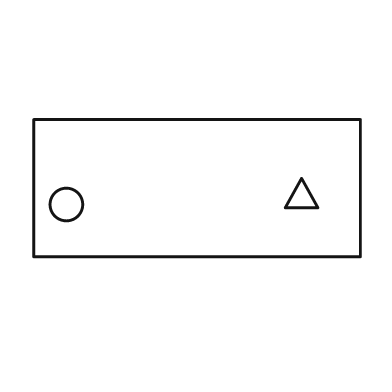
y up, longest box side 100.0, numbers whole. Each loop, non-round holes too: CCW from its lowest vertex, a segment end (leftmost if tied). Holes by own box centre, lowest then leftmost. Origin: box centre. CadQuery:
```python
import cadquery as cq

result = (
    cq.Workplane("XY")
    .moveTo(-50.0, -21.0)
    .lineTo(50.0, -21.0)
    .lineTo(50.0, 21.0)
    .lineTo(-50.0, 21.0)
    .close()
    .moveTo(-40.0, -5.0)
    .circle(5.0)
    .moveTo(27.0, -6.0)
    .lineTo(37.0, -6.0)
    .lineTo(32.0, 3.0)
    .close()
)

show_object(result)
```